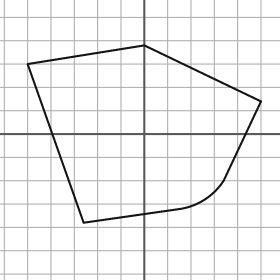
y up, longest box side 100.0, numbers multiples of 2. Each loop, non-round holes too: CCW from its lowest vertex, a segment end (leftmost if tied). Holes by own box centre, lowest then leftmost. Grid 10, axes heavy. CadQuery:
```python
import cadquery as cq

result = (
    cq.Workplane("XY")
    .moveTo(-26.0, -38.0)
    .lineTo(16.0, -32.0)
    .threePointArc((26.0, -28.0), (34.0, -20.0))
    .lineTo(50.0, 14.0)
    .lineTo(0.0, 38.0)
    .lineTo(-50.0, 30.0)
    .close()
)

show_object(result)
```